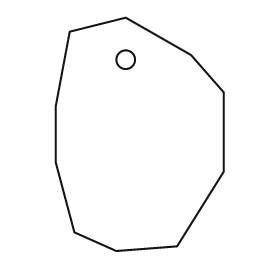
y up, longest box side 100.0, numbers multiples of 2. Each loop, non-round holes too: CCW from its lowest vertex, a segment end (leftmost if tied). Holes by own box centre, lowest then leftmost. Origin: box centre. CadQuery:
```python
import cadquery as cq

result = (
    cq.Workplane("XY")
    .moveTo(-10.0, -50.0)
    .lineTo(16.0, -48.0)
    .lineTo(36.0, -16.0)
    .lineTo(36.0, 18.0)
    .lineTo(22.0, 34.0)
    .lineTo(-6.0, 50.0)
    .lineTo(-30.0, 44.0)
    .lineTo(-36.0, 12.0)
    .lineTo(-36.0, -12.0)
    .lineTo(-28.0, -42.0)
    .close()
    .moveTo(-6.0, 32.0)
    .circle(4.0)
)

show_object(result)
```